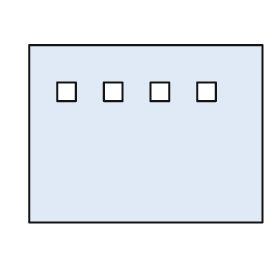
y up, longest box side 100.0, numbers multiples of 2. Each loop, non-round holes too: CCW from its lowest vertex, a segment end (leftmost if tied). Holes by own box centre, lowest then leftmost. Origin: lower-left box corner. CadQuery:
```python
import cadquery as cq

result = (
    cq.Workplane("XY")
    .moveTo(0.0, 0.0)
    .lineTo(100.0, 0.0)
    .lineTo(100.0, 76.0)
    .lineTo(0.0, 76.0)
    .close()
    .moveTo(12.0, 52.0)
    .lineTo(20.0, 52.0)
    .lineTo(20.0, 60.0)
    .lineTo(12.0, 60.0)
    .close()
    .moveTo(32.0, 52.0)
    .lineTo(40.0, 52.0)
    .lineTo(40.0, 60.0)
    .lineTo(32.0, 60.0)
    .close()
    .moveTo(52.0, 52.0)
    .lineTo(60.0, 52.0)
    .lineTo(60.0, 60.0)
    .lineTo(52.0, 60.0)
    .close()
    .moveTo(72.0, 52.0)
    .lineTo(80.0, 52.0)
    .lineTo(80.0, 60.0)
    .lineTo(72.0, 60.0)
    .close()
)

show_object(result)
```